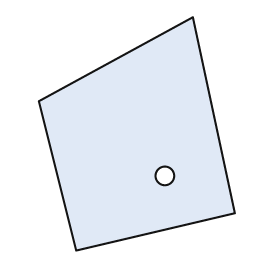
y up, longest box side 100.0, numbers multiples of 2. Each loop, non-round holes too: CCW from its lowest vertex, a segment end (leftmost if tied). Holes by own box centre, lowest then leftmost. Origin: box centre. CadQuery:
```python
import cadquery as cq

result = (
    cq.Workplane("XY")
    .moveTo(-26.0, -50.0)
    .lineTo(42.0, -34.0)
    .lineTo(24.0, 50.0)
    .lineTo(-42.0, 14.0)
    .close()
    .moveTo(12.0, -18.0)
    .circle(4.0)
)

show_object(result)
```